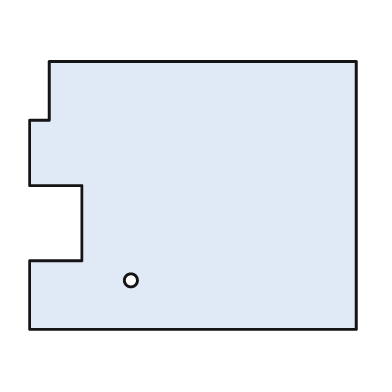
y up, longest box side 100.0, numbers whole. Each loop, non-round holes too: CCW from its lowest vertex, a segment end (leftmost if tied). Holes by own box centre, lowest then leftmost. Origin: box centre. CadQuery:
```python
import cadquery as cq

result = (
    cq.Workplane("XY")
    .moveTo(-50.0, -41.0)
    .lineTo(50.0, -41.0)
    .lineTo(50.0, 41.0)
    .lineTo(-44.0, 41.0)
    .lineTo(-44.0, 23.0)
    .lineTo(-50.0, 23.0)
    .lineTo(-50.0, 3.0)
    .lineTo(-34.0, 3.0)
    .lineTo(-34.0, -20.0)
    .lineTo(-50.0, -20.0)
    .close()
    .moveTo(-19.0, -26.0)
    .circle(2.0)
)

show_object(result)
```